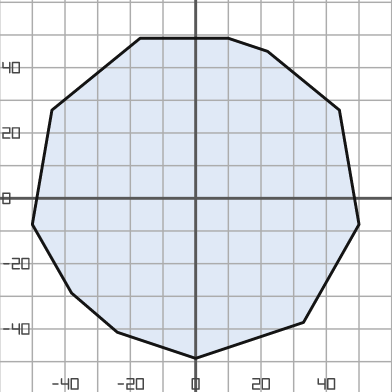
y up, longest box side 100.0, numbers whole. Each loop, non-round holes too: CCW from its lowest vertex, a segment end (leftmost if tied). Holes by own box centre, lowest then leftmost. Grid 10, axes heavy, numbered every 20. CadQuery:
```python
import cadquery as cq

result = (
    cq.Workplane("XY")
    .moveTo(0.0, -49.0)
    .lineTo(33.0, -38.0)
    .lineTo(50.0, -8.0)
    .lineTo(44.0, 27.0)
    .lineTo(22.0, 45.0)
    .lineTo(10.0, 49.0)
    .lineTo(-17.0, 49.0)
    .lineTo(-44.0, 27.0)
    .lineTo(-50.0, -8.0)
    .lineTo(-38.0, -29.0)
    .lineTo(-24.0, -41.0)
    .close()
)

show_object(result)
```